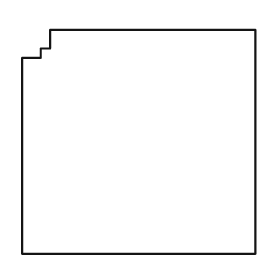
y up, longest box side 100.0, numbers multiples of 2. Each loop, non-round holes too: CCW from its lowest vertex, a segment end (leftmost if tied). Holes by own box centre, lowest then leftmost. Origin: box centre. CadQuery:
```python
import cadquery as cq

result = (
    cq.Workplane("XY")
    .moveTo(-50.0, -48.0)
    .lineTo(50.0, -48.0)
    .lineTo(50.0, 48.0)
    .lineTo(-38.0, 48.0)
    .lineTo(-38.0, 40.0)
    .lineTo(-42.0, 40.0)
    .lineTo(-42.0, 36.0)
    .lineTo(-50.0, 36.0)
    .close()
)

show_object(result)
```